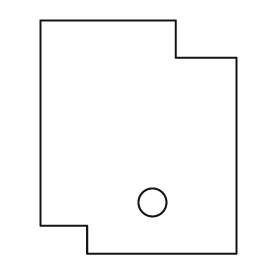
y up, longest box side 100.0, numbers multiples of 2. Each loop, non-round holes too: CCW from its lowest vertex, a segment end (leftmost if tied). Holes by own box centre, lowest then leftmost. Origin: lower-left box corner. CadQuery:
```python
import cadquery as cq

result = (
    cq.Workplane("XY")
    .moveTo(20.0, 0.0)
    .lineTo(84.0, 0.0)
    .lineTo(84.0, 84.0)
    .lineTo(58.0, 84.0)
    .lineTo(58.0, 100.0)
    .lineTo(0.0, 100.0)
    .lineTo(0.0, 12.0)
    .lineTo(20.0, 12.0)
    .close()
    .moveTo(48.0, 22.0)
    .circle(6.0)
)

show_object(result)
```